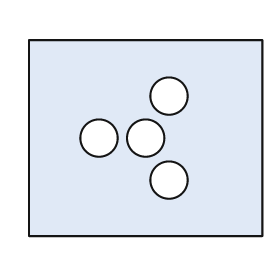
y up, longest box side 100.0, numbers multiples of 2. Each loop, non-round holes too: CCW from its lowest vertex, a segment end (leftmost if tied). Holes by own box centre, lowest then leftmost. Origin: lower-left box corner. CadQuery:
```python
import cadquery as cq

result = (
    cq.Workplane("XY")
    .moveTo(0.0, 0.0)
    .lineTo(100.0, 0.0)
    .lineTo(100.0, 84.0)
    .lineTo(0.0, 84.0)
    .close()
    .moveTo(60.0, 24.0)
    .circle(8.0)
    .moveTo(30.0, 42.0)
    .circle(8.0)
    .moveTo(50.0, 42.0)
    .circle(8.0)
    .moveTo(60.0, 60.0)
    .circle(8.0)
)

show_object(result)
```